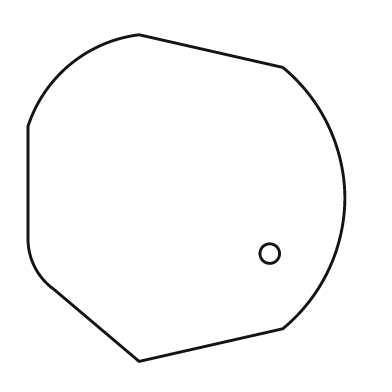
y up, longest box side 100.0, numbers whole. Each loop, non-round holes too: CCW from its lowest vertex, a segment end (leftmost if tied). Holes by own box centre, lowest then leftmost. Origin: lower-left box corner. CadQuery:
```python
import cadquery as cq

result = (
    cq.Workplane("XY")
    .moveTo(34.0, 0.0)
    .lineTo(78.0, 10.0)
    .threePointArc((92.0, 28.0), (97.0, 50.0))
    .threePointArc((92.0, 72.0), (78.0, 90.0))
    .lineTo(34.0, 100.0)
    .threePointArc((13.0, 91.0), (0.0, 72.0))
    .lineTo(0.0, 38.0)
    .threePointArc((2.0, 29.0), (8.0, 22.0))
    .close()
    .moveTo(74.0, 33.0)
    .circle(3.0)
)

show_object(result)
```